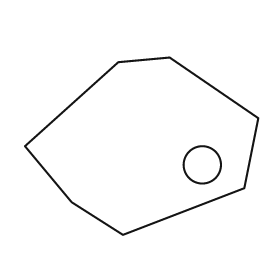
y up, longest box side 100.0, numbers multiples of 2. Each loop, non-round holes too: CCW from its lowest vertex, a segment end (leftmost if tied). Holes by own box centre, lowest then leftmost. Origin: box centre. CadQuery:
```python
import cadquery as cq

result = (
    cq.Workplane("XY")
    .moveTo(-8.0, -38.0)
    .lineTo(44.0, -18.0)
    .lineTo(50.0, 12.0)
    .lineTo(12.0, 38.0)
    .lineTo(-10.0, 36.0)
    .lineTo(-50.0, 0.0)
    .lineTo(-30.0, -24.0)
    .close()
    .moveTo(26.0, -8.0)
    .circle(8.0)
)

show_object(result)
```